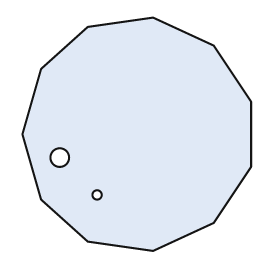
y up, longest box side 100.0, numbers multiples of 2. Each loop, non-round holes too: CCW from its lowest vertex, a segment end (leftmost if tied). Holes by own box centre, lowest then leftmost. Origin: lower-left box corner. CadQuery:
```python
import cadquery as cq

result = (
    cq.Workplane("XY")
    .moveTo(56.0, 0.0)
    .lineTo(82.0, 12.0)
    .lineTo(98.0, 36.0)
    .lineTo(98.0, 64.0)
    .lineTo(82.0, 88.0)
    .lineTo(56.0, 100.0)
    .lineTo(28.0, 96.0)
    .lineTo(8.0, 78.0)
    .lineTo(0.0, 50.0)
    .lineTo(8.0, 22.0)
    .lineTo(28.0, 4.0)
    .close()
    .moveTo(32.0, 24.0)
    .circle(2.0)
    .moveTo(16.0, 40.0)
    .circle(4.0)
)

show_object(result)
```